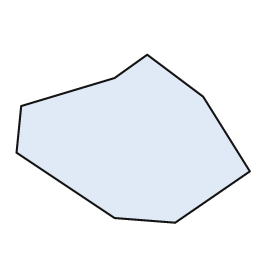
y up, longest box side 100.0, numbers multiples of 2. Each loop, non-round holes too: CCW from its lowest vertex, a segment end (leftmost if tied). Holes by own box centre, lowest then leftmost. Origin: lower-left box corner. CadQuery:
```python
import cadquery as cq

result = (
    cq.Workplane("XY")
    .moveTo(68.0, 0.0)
    .lineTo(100.0, 22.0)
    .lineTo(80.0, 54.0)
    .lineTo(56.0, 72.0)
    .lineTo(42.0, 62.0)
    .lineTo(2.0, 50.0)
    .lineTo(0.0, 30.0)
    .lineTo(42.0, 2.0)
    .close()
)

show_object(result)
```